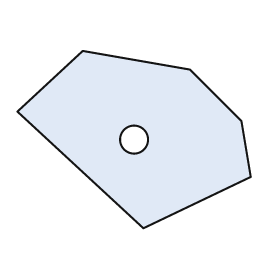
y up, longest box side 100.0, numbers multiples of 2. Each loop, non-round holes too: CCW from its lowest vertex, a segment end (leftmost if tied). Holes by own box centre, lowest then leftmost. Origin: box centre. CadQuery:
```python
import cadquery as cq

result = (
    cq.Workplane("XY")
    .moveTo(4.0, -38.0)
    .lineTo(50.0, -16.0)
    .lineTo(46.0, 8.0)
    .lineTo(24.0, 30.0)
    .lineTo(-22.0, 38.0)
    .lineTo(-50.0, 12.0)
    .close()
    .moveTo(0.0, 0.0)
    .circle(6.0)
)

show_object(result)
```